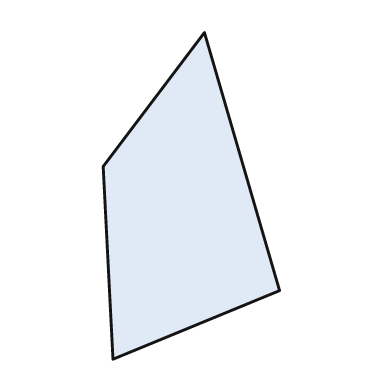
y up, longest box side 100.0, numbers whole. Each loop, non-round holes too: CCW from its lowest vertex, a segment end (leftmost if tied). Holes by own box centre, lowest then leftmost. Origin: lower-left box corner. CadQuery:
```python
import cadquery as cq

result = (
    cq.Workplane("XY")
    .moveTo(3.0, 0.0)
    .lineTo(54.0, 21.0)
    .lineTo(31.0, 100.0)
    .lineTo(0.0, 59.0)
    .close()
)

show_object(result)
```